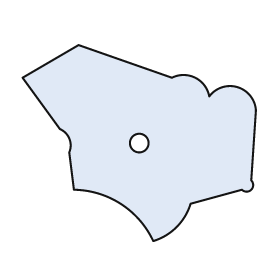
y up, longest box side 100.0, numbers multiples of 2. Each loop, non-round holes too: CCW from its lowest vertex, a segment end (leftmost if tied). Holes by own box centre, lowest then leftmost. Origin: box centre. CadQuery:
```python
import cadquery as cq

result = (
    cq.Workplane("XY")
    .moveTo(6.0, -42.0)
    .threePointArc((16.0, -36.0), (22.0, -26.0))
    .lineTo(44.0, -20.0)
    .threePointArc((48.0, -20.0), (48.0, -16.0))
    .lineTo(50.0, 14.0)
    .threePointArc((42.0, 24.0), (30.0, 20.0))
    .threePointArc((24.0, 28.0), (14.0, 28.0))
    .lineTo(-26.0, 42.0)
    .lineTo(-50.0, 28.0)
    .lineTo(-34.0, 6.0)
    .threePointArc((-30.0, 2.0), (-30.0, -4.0))
    .lineTo(-28.0, -20.0)
    .threePointArc((-8.0, -26.0), (6.0, -42.0))
    .close()
    .moveTo(0.0, 0.0)
    .circle(4.0)
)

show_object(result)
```